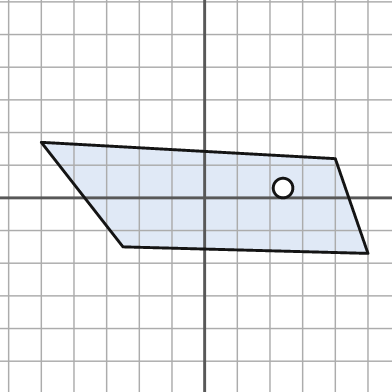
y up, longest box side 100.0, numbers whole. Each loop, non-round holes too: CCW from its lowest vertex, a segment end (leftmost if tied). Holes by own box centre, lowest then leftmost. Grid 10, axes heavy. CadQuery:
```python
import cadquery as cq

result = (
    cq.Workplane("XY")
    .moveTo(50.0, -17.0)
    .lineTo(40.0, 12.0)
    .lineTo(-50.0, 17.0)
    .lineTo(-25.0, -15.0)
    .close()
    .moveTo(24.0, 3.0)
    .circle(3.0)
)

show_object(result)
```